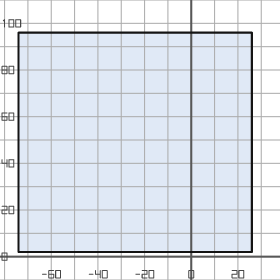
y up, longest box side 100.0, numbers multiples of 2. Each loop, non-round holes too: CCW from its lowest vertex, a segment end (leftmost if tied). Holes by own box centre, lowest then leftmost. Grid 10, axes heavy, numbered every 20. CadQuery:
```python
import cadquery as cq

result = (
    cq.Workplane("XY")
    .moveTo(-74.0, 2.0)
    .lineTo(26.0, 2.0)
    .lineTo(26.0, 96.0)
    .lineTo(-74.0, 96.0)
    .close()
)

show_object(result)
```